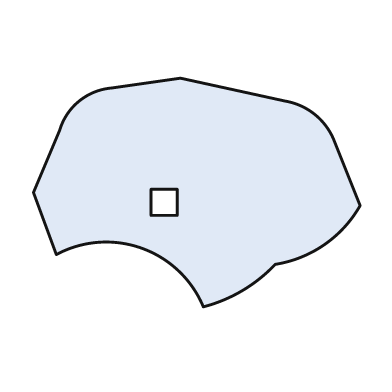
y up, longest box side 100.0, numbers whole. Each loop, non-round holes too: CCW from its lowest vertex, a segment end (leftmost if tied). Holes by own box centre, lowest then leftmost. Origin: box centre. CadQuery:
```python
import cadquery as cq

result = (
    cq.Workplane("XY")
    .moveTo(2.0, -35.0)
    .threePointArc((14.0, -30.0), (24.0, -22.0))
    .threePointArc((39.0, -16.0), (50.0, -4.0))
    .lineTo(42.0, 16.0)
    .threePointArc((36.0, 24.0), (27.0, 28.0))
    .lineTo(-5.0, 35.0)
    .lineTo(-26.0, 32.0)
    .threePointArc((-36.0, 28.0), (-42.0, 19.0))
    .lineTo(-50.0, 0.0)
    .lineTo(-43.0, -19.0)
    .threePointArc((-17.0, -17.0), (2.0, -35.0))
    .close()
    .moveTo(-14.0, -7.0)
    .lineTo(-6.0, -7.0)
    .lineTo(-6.0, 1.0)
    .lineTo(-14.0, 1.0)
    .close()
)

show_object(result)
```